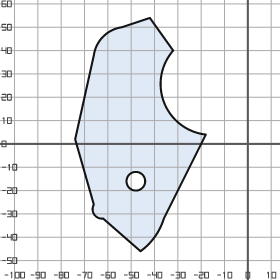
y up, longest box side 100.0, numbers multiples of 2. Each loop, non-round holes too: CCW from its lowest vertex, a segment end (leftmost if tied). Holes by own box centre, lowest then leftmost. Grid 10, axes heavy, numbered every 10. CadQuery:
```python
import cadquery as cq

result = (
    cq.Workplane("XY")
    .moveTo(-46.0, -46.0)
    .threePointArc((-40.0, -40.0), (-36.0, -32.0))
    .lineTo(-18.0, 4.0)
    .threePointArc((-36.0, 18.0), (-32.0, 40.0))
    .lineTo(-42.0, 54.0)
    .lineTo(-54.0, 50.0)
    .threePointArc((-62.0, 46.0), (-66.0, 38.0))
    .lineTo(-74.0, 2.0)
    .lineTo(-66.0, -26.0)
    .threePointArc((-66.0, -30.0), (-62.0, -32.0))
    .close()
    .moveTo(-48.0, -16.0)
    .circle(4.0)
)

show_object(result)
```